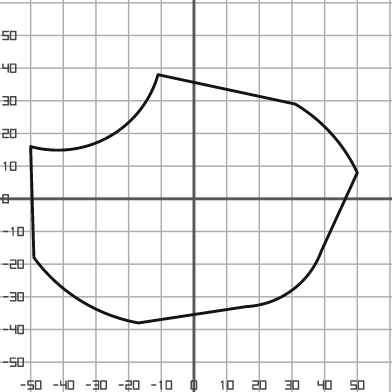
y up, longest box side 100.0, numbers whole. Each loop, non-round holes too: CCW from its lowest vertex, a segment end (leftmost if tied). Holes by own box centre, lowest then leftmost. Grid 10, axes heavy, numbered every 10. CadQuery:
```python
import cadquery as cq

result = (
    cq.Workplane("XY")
    .moveTo(-17.0, -38.0)
    .lineTo(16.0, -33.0)
    .threePointArc((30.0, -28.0), (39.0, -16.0))
    .lineTo(50.0, 8.0)
    .threePointArc((42.0, 20.0), (31.0, 29.0))
    .lineTo(-11.0, 38.0)
    .threePointArc((-26.0, 19.0), (-50.0, 16.0))
    .lineTo(-49.0, -18.0)
    .threePointArc((-35.0, -31.0), (-17.0, -38.0))
    .close()
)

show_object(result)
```